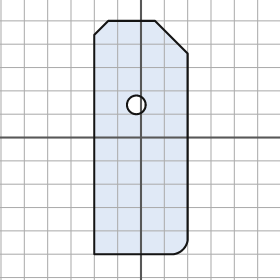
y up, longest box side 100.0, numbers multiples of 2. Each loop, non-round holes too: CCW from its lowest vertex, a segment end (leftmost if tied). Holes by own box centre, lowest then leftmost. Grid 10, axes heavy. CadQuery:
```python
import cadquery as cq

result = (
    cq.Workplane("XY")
    .moveTo(-20.0, -50.0)
    .lineTo(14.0, -50.0)
    .threePointArc((18.0, -48.0), (20.0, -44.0))
    .lineTo(20.0, 36.0)
    .lineTo(6.0, 50.0)
    .lineTo(-14.0, 50.0)
    .lineTo(-20.0, 44.0)
    .close()
    .moveTo(-2.0, 14.0)
    .circle(4.0)
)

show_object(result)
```